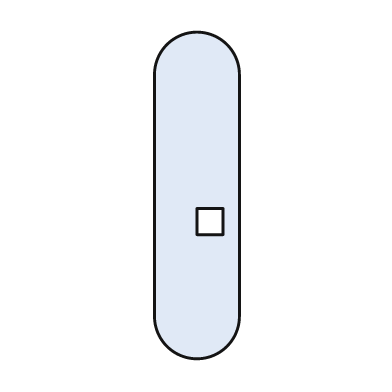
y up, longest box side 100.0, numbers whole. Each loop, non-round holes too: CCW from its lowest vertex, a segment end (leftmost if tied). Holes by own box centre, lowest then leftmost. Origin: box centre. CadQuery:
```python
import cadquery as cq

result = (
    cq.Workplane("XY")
    .moveTo(-13.0, -37.0)
    .threePointArc((0.0, -50.0), (13.0, -37.0))
    .lineTo(13.0, 37.0)
    .threePointArc((0.0, 50.0), (-13.0, 37.0))
    .close()
    .moveTo(0.0, -12.0)
    .lineTo(8.0, -12.0)
    .lineTo(8.0, -4.0)
    .lineTo(0.0, -4.0)
    .close()
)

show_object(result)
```